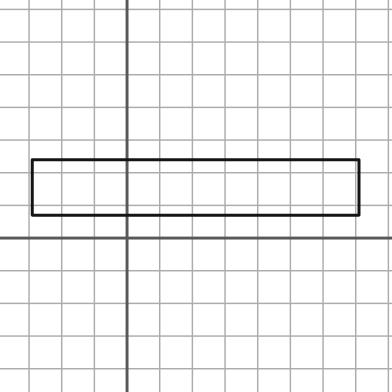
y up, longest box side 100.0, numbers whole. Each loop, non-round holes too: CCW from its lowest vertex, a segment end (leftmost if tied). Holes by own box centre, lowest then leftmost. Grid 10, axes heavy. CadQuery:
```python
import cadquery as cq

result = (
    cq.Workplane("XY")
    .moveTo(-29.0, 7.0)
    .lineTo(71.0, 7.0)
    .lineTo(71.0, 24.0)
    .lineTo(-29.0, 24.0)
    .close()
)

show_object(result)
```